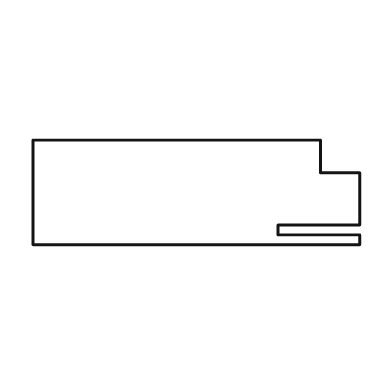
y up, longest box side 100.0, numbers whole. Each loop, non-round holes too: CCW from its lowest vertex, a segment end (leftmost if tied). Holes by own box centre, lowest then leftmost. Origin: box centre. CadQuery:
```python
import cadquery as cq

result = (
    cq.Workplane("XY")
    .moveTo(-50.0, -16.0)
    .lineTo(50.0, -16.0)
    .lineTo(50.0, -13.0)
    .lineTo(25.0, -13.0)
    .lineTo(25.0, -10.0)
    .lineTo(50.0, -10.0)
    .lineTo(50.0, 6.0)
    .lineTo(38.0, 6.0)
    .lineTo(38.0, 16.0)
    .lineTo(-50.0, 16.0)
    .close()
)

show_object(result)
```